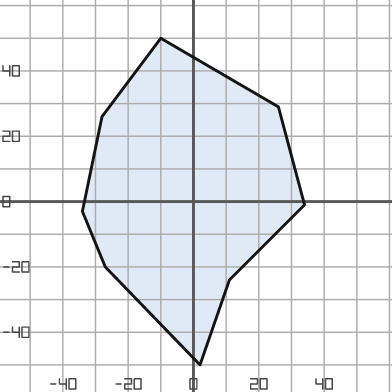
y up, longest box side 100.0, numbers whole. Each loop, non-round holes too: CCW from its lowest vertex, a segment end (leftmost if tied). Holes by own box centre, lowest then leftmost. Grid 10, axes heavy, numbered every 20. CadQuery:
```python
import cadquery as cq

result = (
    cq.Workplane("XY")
    .moveTo(2.0, -50.0)
    .lineTo(11.0, -24.0)
    .lineTo(34.0, -1.0)
    .lineTo(26.0, 29.0)
    .lineTo(-10.0, 50.0)
    .lineTo(-28.0, 26.0)
    .lineTo(-34.0, -3.0)
    .lineTo(-27.0, -20.0)
    .close()
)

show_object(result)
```